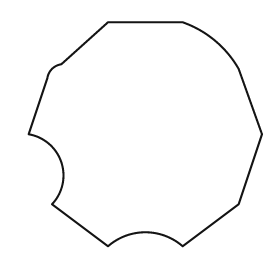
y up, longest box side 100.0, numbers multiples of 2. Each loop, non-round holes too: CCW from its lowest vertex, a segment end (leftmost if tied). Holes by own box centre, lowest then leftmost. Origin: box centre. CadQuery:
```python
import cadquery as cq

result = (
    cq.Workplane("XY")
    .moveTo(-16.0, -48.0)
    .threePointArc((0.0, -42.0), (16.0, -48.0))
    .lineTo(40.0, -30.0)
    .lineTo(50.0, 0.0)
    .lineTo(40.0, 28.0)
    .threePointArc((30.0, 40.0), (16.0, 48.0))
    .lineTo(-16.0, 48.0)
    .lineTo(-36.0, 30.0)
    .threePointArc((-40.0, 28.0), (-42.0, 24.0))
    .lineTo(-50.0, 0.0)
    .threePointArc((-36.0, -12.0), (-40.0, -30.0))
    .close()
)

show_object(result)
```